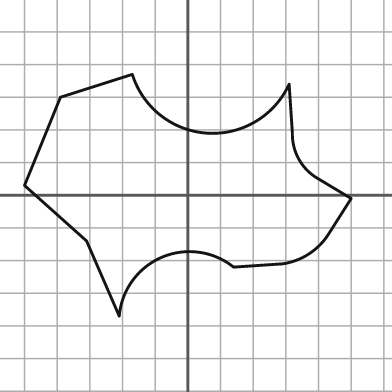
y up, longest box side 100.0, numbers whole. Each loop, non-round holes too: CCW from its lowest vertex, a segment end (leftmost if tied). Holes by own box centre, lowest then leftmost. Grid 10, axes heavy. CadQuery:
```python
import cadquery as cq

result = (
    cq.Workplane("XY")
    .moveTo(-21.0, -37.0)
    .threePointArc((-8.0, -19.0), (14.0, -22.0))
    .lineTo(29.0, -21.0)
    .threePointArc((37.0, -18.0), (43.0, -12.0))
    .lineTo(50.0, -1.0)
    .lineTo(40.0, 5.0)
    .threePointArc((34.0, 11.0), (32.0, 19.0))
    .lineTo(31.0, 34.0)
    .threePointArc((6.0, 19.0), (-17.0, 37.0))
    .lineTo(-39.0, 30.0)
    .lineTo(-50.0, 3.0)
    .lineTo(-31.0, -14.0)
    .close()
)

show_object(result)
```